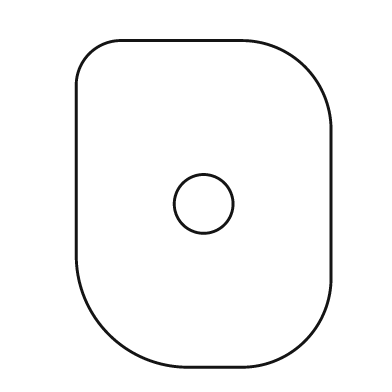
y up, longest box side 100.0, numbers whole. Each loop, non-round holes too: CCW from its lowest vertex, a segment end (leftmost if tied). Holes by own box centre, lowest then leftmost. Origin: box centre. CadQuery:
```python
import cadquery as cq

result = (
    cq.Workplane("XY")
    .moveTo(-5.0, -50.0)
    .lineTo(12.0, -50.0)
    .threePointArc((31.0, -42.0), (39.0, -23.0))
    .lineTo(39.0, 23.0)
    .threePointArc((31.0, 42.0), (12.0, 50.0))
    .lineTo(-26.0, 50.0)
    .threePointArc((-35.0, 46.0), (-39.0, 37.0))
    .lineTo(-39.0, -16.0)
    .threePointArc((-29.0, -40.0), (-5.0, -50.0))
    .close()
    .moveTo(0.0, 0.0)
    .circle(9.0)
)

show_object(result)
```